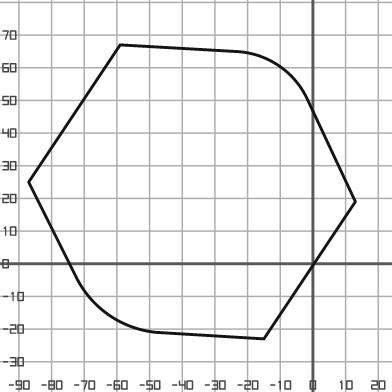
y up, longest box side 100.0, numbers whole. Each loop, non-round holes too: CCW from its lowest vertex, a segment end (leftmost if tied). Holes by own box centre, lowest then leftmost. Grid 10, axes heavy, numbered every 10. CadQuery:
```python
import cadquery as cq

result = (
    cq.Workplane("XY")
    .moveTo(-15.0, -23.0)
    .lineTo(13.0, 19.0)
    .lineTo(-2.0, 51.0)
    .threePointArc((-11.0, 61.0), (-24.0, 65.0))
    .lineTo(-59.0, 67.0)
    .lineTo(-87.0, 25.0)
    .lineTo(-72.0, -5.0)
    .threePointArc((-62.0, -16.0), (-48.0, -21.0))
    .close()
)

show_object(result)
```